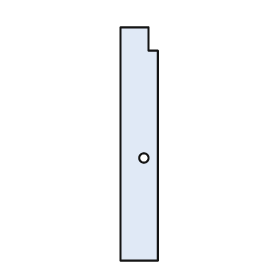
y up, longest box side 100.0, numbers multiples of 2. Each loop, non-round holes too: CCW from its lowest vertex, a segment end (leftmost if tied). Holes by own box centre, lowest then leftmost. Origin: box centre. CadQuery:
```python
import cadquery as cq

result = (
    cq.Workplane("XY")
    .moveTo(-8.0, -50.0)
    .lineTo(8.0, -50.0)
    .lineTo(8.0, 40.0)
    .lineTo(4.0, 40.0)
    .lineTo(4.0, 50.0)
    .lineTo(-8.0, 50.0)
    .close()
    .moveTo(2.0, -6.0)
    .circle(2.0)
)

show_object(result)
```